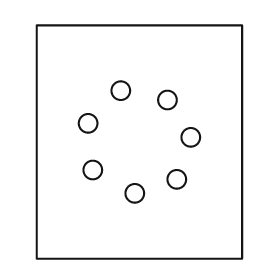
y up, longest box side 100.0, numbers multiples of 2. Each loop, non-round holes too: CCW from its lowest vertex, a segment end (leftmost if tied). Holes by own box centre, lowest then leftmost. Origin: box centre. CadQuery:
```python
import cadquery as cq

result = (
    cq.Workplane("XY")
    .moveTo(-44.0, -50.0)
    .lineTo(44.0, -50.0)
    .lineTo(44.0, 50.0)
    .lineTo(-44.0, 50.0)
    .close()
    .moveTo(-2.0, -22.0)
    .circle(4.0)
    .moveTo(16.0, -16.0)
    .circle(4.0)
    .moveTo(-20.0, -12.0)
    .circle(4.0)
    .moveTo(22.0, 2.0)
    .circle(4.0)
    .moveTo(-22.0, 8.0)
    .circle(4.0)
    .moveTo(12.0, 18.0)
    .circle(4.0)
    .moveTo(-8.0, 22.0)
    .circle(4.0)
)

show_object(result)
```